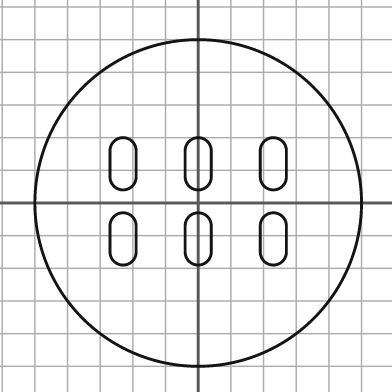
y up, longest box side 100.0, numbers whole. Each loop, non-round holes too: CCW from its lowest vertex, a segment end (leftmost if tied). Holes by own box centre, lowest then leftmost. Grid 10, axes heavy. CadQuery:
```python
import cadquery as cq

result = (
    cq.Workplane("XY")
    .moveTo(0.0, 0.0)
    .circle(50.0)
    .moveTo(-27.0, -15.0)
    .threePointArc((-23.0, -19.0), (-19.0, -15.0))
    .lineTo(-19.0, -7.0)
    .threePointArc((-23.0, -3.0), (-27.0, -7.0))
    .close()
    .moveTo(-4.0, -15.0)
    .threePointArc((0.0, -19.0), (4.0, -15.0))
    .lineTo(4.0, -7.0)
    .threePointArc((0.0, -3.0), (-4.0, -7.0))
    .close()
    .moveTo(19.0, -15.0)
    .threePointArc((23.0, -19.0), (27.0, -15.0))
    .lineTo(27.0, -7.0)
    .threePointArc((23.0, -3.0), (19.0, -7.0))
    .close()
    .moveTo(-27.0, 8.0)
    .threePointArc((-23.0, 4.0), (-19.0, 8.0))
    .lineTo(-19.0, 16.0)
    .threePointArc((-23.0, 20.0), (-27.0, 16.0))
    .close()
    .moveTo(-4.0, 8.0)
    .threePointArc((0.0, 4.0), (4.0, 8.0))
    .lineTo(4.0, 16.0)
    .threePointArc((0.0, 20.0), (-4.0, 16.0))
    .close()
    .moveTo(19.0, 8.0)
    .threePointArc((23.0, 4.0), (27.0, 8.0))
    .lineTo(27.0, 16.0)
    .threePointArc((23.0, 20.0), (19.0, 16.0))
    .close()
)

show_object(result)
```